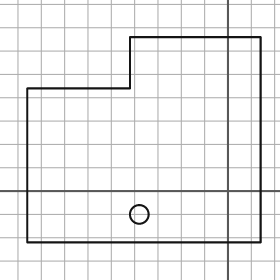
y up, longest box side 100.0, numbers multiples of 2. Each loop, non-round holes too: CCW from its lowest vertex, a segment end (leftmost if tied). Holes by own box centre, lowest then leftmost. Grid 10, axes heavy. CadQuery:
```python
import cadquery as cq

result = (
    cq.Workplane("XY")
    .moveTo(-86.0, -22.0)
    .lineTo(14.0, -22.0)
    .lineTo(14.0, 66.0)
    .lineTo(-42.0, 66.0)
    .lineTo(-42.0, 44.0)
    .lineTo(-86.0, 44.0)
    .close()
    .moveTo(-38.0, -10.0)
    .circle(4.0)
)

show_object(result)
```